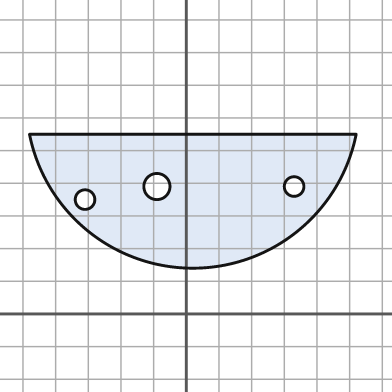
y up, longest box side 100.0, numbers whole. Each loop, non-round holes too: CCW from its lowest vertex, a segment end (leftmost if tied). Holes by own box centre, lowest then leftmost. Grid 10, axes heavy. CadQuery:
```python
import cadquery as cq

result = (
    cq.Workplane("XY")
    .moveTo(-48.0, 55.0)
    .threePointArc((2.0, 14.0), (52.0, 55.0))
    .close()
    .moveTo(-31.0, 35.0)
    .circle(3.0)
    .moveTo(-9.0, 39.0)
    .circle(4.0)
    .moveTo(33.0, 39.0)
    .circle(3.0)
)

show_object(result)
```